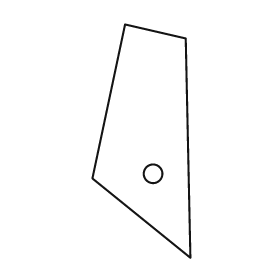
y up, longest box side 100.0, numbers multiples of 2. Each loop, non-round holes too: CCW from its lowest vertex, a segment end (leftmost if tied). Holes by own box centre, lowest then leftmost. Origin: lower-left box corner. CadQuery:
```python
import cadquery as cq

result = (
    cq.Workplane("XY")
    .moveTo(42.0, 0.0)
    .lineTo(40.0, 94.0)
    .lineTo(14.0, 100.0)
    .lineTo(0.0, 34.0)
    .close()
    .moveTo(26.0, 36.0)
    .circle(4.0)
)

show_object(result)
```